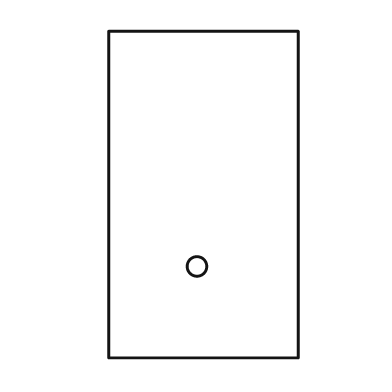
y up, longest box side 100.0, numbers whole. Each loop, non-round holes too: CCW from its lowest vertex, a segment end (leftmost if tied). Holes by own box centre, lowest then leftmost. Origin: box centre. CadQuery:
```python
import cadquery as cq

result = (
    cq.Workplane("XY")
    .moveTo(-29.0, -50.0)
    .lineTo(29.0, -50.0)
    .lineTo(29.0, 50.0)
    .lineTo(-29.0, 50.0)
    .close()
    .moveTo(-2.0, -22.0)
    .circle(3.0)
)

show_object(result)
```